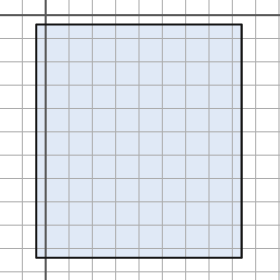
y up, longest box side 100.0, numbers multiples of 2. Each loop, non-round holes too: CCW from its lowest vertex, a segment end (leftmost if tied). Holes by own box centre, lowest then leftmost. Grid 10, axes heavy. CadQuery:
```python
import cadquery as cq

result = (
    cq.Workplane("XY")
    .moveTo(-4.0, -104.0)
    .lineTo(84.0, -104.0)
    .lineTo(84.0, -4.0)
    .lineTo(-4.0, -4.0)
    .close()
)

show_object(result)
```